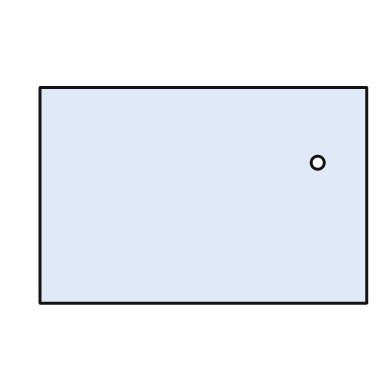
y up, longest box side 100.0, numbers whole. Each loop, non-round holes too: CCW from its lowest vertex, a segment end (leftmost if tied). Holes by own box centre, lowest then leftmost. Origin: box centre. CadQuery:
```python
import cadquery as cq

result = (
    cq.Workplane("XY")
    .moveTo(-50.0, -33.0)
    .lineTo(50.0, -33.0)
    .lineTo(50.0, 33.0)
    .lineTo(-50.0, 33.0)
    .close()
    .moveTo(35.0, 10.0)
    .circle(2.0)
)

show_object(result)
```